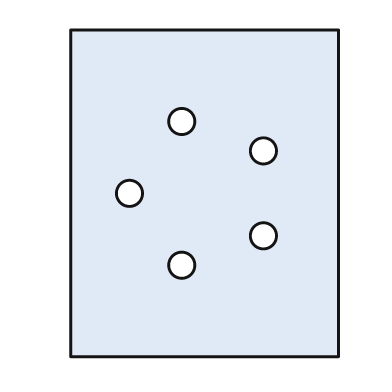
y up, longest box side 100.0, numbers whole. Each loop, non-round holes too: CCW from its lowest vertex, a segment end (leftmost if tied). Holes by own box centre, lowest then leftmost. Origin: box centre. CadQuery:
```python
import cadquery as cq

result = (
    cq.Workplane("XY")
    .moveTo(-41.0, -50.0)
    .lineTo(41.0, -50.0)
    .lineTo(41.0, 50.0)
    .lineTo(-41.0, 50.0)
    .close()
    .moveTo(-7.0, -22.0)
    .circle(4.0)
    .moveTo(18.0, -13.0)
    .circle(4.0)
    .moveTo(-23.0, 0.0)
    .circle(4.0)
    .moveTo(18.0, 13.0)
    .circle(4.0)
    .moveTo(-7.0, 22.0)
    .circle(4.0)
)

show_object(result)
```